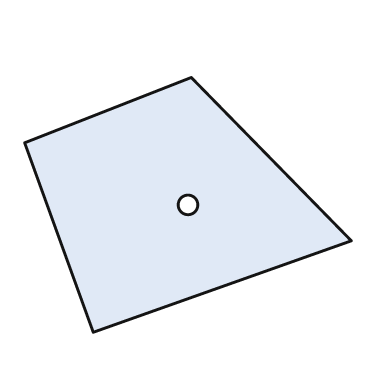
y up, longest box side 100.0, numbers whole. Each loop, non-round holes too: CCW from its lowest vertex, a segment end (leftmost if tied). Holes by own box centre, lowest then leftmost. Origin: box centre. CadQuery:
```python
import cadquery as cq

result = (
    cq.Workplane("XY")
    .moveTo(-29.0, -39.0)
    .lineTo(50.0, -11.0)
    .lineTo(1.0, 39.0)
    .lineTo(-50.0, 19.0)
    .close()
    .moveTo(0.0, 0.0)
    .circle(3.0)
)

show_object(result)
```